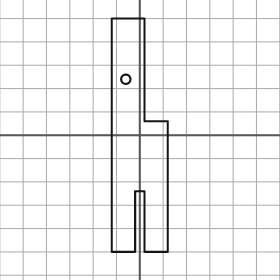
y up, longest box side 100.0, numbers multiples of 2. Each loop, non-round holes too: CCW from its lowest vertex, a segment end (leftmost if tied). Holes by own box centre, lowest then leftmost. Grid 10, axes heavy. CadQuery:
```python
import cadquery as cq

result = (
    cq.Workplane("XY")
    .moveTo(-12.0, -50.0)
    .lineTo(-2.0, -50.0)
    .lineTo(-2.0, -24.0)
    .lineTo(2.0, -24.0)
    .lineTo(2.0, -50.0)
    .lineTo(12.0, -50.0)
    .lineTo(12.0, 6.0)
    .lineTo(2.0, 6.0)
    .lineTo(2.0, 50.0)
    .lineTo(-12.0, 50.0)
    .close()
    .moveTo(-6.0, 24.0)
    .circle(2.0)
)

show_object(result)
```